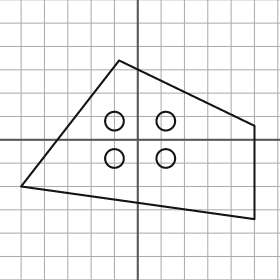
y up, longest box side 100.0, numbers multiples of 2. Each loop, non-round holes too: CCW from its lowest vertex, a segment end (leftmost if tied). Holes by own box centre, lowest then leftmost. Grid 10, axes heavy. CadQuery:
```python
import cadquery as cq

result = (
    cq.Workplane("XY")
    .moveTo(50.0, -34.0)
    .lineTo(50.0, 6.0)
    .lineTo(-8.0, 34.0)
    .lineTo(-50.0, -20.0)
    .close()
    .moveTo(-10.0, -8.0)
    .circle(4.0)
    .moveTo(12.0, -8.0)
    .circle(4.0)
    .moveTo(-10.0, 8.0)
    .circle(4.0)
    .moveTo(12.0, 8.0)
    .circle(4.0)
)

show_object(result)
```